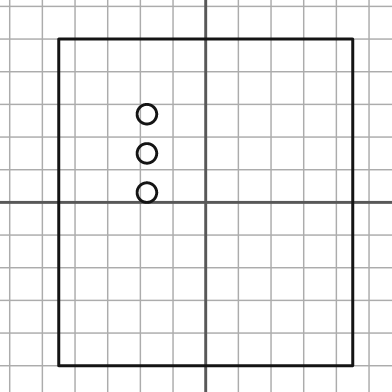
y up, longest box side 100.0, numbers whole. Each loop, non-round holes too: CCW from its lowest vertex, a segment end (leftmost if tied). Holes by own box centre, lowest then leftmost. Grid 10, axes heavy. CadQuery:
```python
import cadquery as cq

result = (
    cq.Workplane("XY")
    .moveTo(-45.0, -50.0)
    .lineTo(45.0, -50.0)
    .lineTo(45.0, 50.0)
    .lineTo(-45.0, 50.0)
    .close()
    .moveTo(-18.0, 3.0)
    .circle(3.0)
    .moveTo(-18.0, 15.0)
    .circle(3.0)
    .moveTo(-18.0, 27.0)
    .circle(3.0)
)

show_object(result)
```